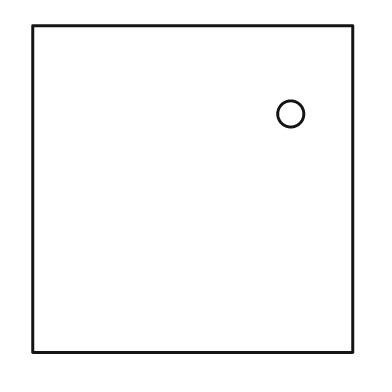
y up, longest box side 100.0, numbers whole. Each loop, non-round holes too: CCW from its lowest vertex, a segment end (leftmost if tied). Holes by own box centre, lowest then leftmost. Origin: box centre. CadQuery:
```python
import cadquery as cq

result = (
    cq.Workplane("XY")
    .moveTo(-49.0, -50.0)
    .lineTo(49.0, -50.0)
    .lineTo(49.0, 50.0)
    .lineTo(-49.0, 50.0)
    .close()
    .moveTo(30.0, 23.0)
    .circle(4.0)
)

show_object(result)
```